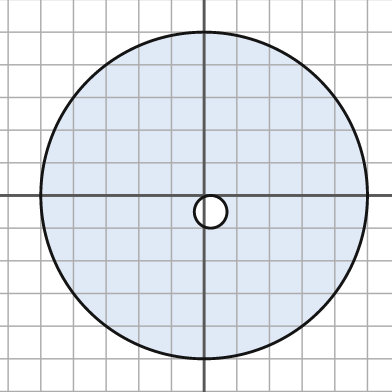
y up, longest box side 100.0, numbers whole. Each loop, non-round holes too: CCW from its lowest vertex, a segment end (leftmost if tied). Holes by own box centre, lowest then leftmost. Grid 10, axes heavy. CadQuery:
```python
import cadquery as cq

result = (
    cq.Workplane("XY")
    .moveTo(0.0, 0.0)
    .circle(50.0)
    .moveTo(2.0, -5.0)
    .circle(5.0)
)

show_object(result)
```